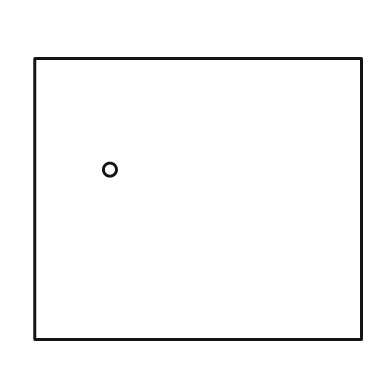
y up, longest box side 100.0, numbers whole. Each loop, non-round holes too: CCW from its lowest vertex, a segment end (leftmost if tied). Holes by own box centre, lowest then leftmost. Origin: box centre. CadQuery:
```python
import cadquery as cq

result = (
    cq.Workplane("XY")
    .moveTo(-50.0, -43.0)
    .lineTo(50.0, -43.0)
    .lineTo(50.0, 43.0)
    .lineTo(-50.0, 43.0)
    .close()
    .moveTo(-27.0, 9.0)
    .circle(2.0)
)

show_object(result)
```